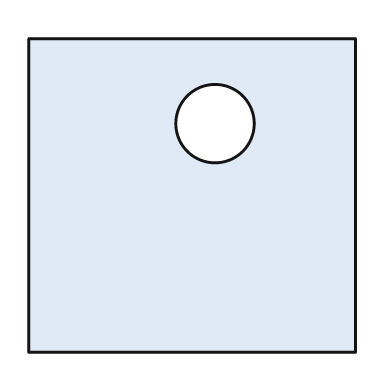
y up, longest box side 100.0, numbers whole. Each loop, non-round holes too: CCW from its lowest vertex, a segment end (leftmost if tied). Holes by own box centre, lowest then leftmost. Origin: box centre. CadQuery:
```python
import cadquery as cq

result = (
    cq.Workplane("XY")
    .moveTo(-50.0, -48.0)
    .lineTo(50.0, -48.0)
    .lineTo(50.0, 48.0)
    .lineTo(-50.0, 48.0)
    .close()
    .moveTo(7.0, 22.0)
    .circle(12.0)
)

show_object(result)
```